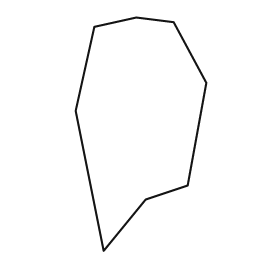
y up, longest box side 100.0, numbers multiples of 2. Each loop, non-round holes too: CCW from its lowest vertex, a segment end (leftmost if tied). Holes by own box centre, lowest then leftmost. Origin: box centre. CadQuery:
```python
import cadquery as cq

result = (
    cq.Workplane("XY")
    .moveTo(-16.0, -50.0)
    .lineTo(2.0, -28.0)
    .lineTo(20.0, -22.0)
    .lineTo(28.0, 22.0)
    .lineTo(14.0, 48.0)
    .lineTo(-2.0, 50.0)
    .lineTo(-20.0, 46.0)
    .lineTo(-28.0, 10.0)
    .close()
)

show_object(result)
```